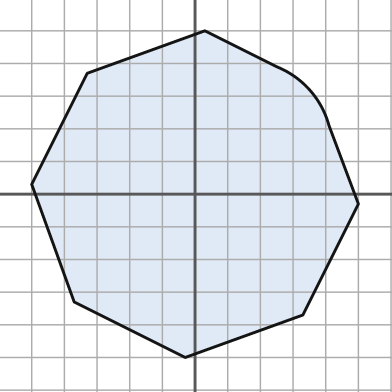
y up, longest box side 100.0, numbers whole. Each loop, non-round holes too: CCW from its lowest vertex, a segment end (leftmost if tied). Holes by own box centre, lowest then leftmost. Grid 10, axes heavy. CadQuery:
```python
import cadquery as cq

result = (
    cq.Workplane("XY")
    .moveTo(-3.0, -50.0)
    .lineTo(33.0, -37.0)
    .lineTo(50.0, -3.0)
    .lineTo(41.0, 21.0)
    .threePointArc((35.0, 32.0), (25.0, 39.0))
    .lineTo(3.0, 50.0)
    .lineTo(-33.0, 37.0)
    .lineTo(-50.0, 3.0)
    .lineTo(-37.0, -33.0)
    .close()
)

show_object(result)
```